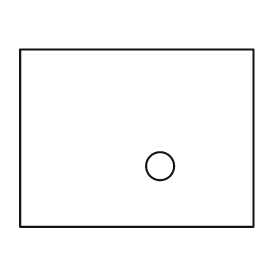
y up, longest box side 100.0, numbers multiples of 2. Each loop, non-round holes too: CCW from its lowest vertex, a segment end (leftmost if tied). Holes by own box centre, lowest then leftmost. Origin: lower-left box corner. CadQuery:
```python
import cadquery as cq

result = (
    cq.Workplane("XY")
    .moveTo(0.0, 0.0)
    .lineTo(100.0, 0.0)
    .lineTo(100.0, 76.0)
    .lineTo(0.0, 76.0)
    .close()
    .moveTo(60.0, 26.0)
    .circle(6.0)
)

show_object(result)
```